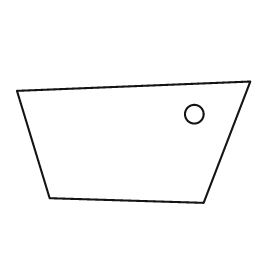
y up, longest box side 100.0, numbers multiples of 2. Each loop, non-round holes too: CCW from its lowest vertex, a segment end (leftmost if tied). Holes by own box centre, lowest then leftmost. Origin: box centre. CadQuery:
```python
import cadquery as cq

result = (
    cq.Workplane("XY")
    .moveTo(30.0, -26.0)
    .lineTo(50.0, 26.0)
    .lineTo(-50.0, 22.0)
    .lineTo(-36.0, -24.0)
    .close()
    .moveTo(26.0, 12.0)
    .circle(4.0)
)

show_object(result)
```